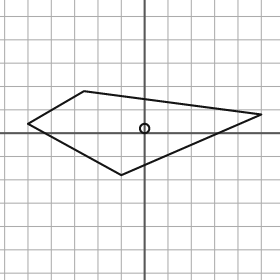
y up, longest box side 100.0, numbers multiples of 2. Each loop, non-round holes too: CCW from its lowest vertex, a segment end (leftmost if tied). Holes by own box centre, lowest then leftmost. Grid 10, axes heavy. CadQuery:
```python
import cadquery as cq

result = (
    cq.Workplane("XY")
    .moveTo(-10.0, -18.0)
    .lineTo(50.0, 8.0)
    .lineTo(-26.0, 18.0)
    .lineTo(-50.0, 4.0)
    .close()
    .moveTo(0.0, 2.0)
    .circle(2.0)
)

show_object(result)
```